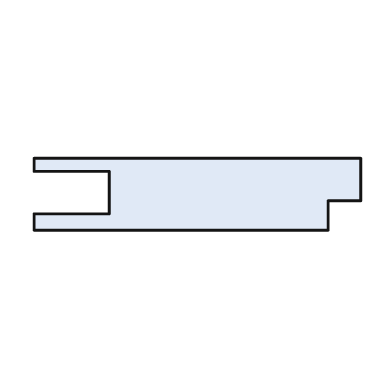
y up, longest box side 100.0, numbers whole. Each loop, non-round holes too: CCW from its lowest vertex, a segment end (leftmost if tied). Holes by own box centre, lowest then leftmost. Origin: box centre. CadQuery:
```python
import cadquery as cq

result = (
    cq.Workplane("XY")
    .moveTo(-50.0, -11.0)
    .lineTo(40.0, -11.0)
    .lineTo(40.0, -2.0)
    .lineTo(50.0, -2.0)
    .lineTo(50.0, 11.0)
    .lineTo(-50.0, 11.0)
    .lineTo(-50.0, 7.0)
    .lineTo(-27.0, 7.0)
    .lineTo(-27.0, -6.0)
    .lineTo(-50.0, -6.0)
    .close()
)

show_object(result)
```